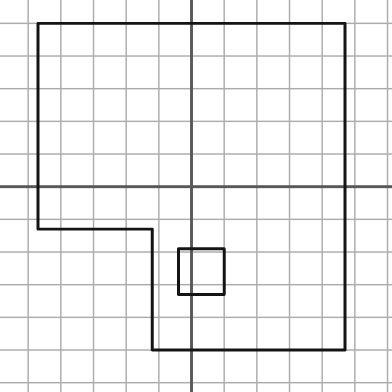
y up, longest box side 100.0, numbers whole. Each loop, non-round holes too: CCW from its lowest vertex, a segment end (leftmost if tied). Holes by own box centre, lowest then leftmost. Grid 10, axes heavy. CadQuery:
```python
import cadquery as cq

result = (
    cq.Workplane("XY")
    .moveTo(-12.0, -50.0)
    .lineTo(47.0, -50.0)
    .lineTo(47.0, 50.0)
    .lineTo(-47.0, 50.0)
    .lineTo(-47.0, -13.0)
    .lineTo(-12.0, -13.0)
    .close()
    .moveTo(-4.0, -33.0)
    .lineTo(10.0, -33.0)
    .lineTo(10.0, -19.0)
    .lineTo(-4.0, -19.0)
    .close()
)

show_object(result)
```